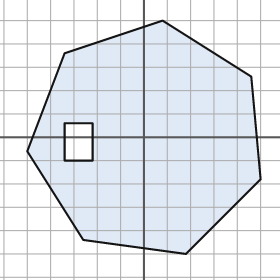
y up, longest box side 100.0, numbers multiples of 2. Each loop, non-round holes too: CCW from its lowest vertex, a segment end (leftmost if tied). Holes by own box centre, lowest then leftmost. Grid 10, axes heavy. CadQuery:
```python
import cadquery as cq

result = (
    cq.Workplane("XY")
    .moveTo(18.0, -50.0)
    .lineTo(50.0, -18.0)
    .lineTo(46.0, 26.0)
    .lineTo(8.0, 50.0)
    .lineTo(-34.0, 36.0)
    .lineTo(-50.0, -6.0)
    .lineTo(-26.0, -44.0)
    .close()
    .moveTo(-34.0, -10.0)
    .lineTo(-22.0, -10.0)
    .lineTo(-22.0, 6.0)
    .lineTo(-34.0, 6.0)
    .close()
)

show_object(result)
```